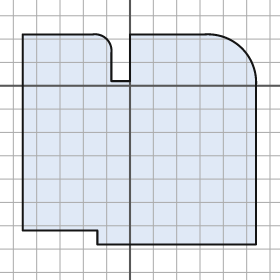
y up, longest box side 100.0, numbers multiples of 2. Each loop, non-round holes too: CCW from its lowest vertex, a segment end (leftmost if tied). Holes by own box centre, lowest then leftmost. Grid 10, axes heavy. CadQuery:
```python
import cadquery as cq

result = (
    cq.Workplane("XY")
    .moveTo(-14.0, -68.0)
    .lineTo(54.0, -68.0)
    .lineTo(54.0, 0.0)
    .threePointArc((48.0, 16.0), (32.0, 22.0))
    .lineTo(0.0, 22.0)
    .lineTo(0.0, 2.0)
    .lineTo(-8.0, 2.0)
    .lineTo(-8.0, 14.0)
    .threePointArc((-10.0, 20.0), (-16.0, 22.0))
    .lineTo(-46.0, 22.0)
    .lineTo(-46.0, -62.0)
    .lineTo(-14.0, -62.0)
    .close()
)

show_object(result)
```